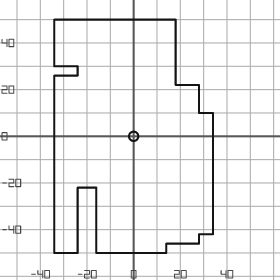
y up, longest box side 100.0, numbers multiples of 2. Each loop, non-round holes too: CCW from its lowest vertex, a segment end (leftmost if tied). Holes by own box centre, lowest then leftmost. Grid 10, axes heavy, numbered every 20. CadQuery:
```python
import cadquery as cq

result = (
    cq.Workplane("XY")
    .moveTo(-34.0, -50.0)
    .lineTo(-24.0, -50.0)
    .lineTo(-24.0, -22.0)
    .lineTo(-16.0, -22.0)
    .lineTo(-16.0, -50.0)
    .lineTo(14.0, -50.0)
    .lineTo(14.0, -46.0)
    .lineTo(28.0, -46.0)
    .lineTo(28.0, -42.0)
    .lineTo(34.0, -42.0)
    .lineTo(34.0, 10.0)
    .lineTo(28.0, 10.0)
    .lineTo(28.0, 22.0)
    .lineTo(18.0, 22.0)
    .lineTo(18.0, 50.0)
    .lineTo(-34.0, 50.0)
    .lineTo(-34.0, 30.0)
    .lineTo(-24.0, 30.0)
    .lineTo(-24.0, 26.0)
    .lineTo(-34.0, 26.0)
    .close()
    .moveTo(0.0, 0.0)
    .circle(2.0)
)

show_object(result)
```